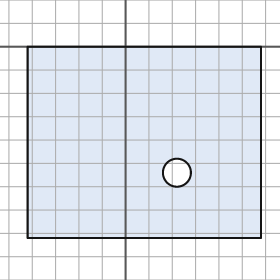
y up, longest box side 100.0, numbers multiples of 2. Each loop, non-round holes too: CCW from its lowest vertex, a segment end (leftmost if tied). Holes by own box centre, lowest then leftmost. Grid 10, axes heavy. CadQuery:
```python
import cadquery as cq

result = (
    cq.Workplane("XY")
    .moveTo(-42.0, -82.0)
    .lineTo(58.0, -82.0)
    .lineTo(58.0, 0.0)
    .lineTo(-42.0, 0.0)
    .close()
    .moveTo(22.0, -54.0)
    .circle(6.0)
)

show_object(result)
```